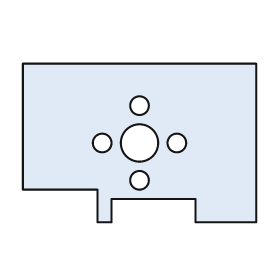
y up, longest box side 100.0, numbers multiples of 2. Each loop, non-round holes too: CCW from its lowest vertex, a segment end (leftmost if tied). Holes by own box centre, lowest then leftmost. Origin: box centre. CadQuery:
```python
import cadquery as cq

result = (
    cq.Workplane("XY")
    .moveTo(-18.0, -34.0)
    .lineTo(-12.0, -34.0)
    .lineTo(-12.0, -24.0)
    .lineTo(24.0, -24.0)
    .lineTo(24.0, -34.0)
    .lineTo(50.0, -34.0)
    .lineTo(50.0, 34.0)
    .lineTo(-50.0, 34.0)
    .lineTo(-50.0, -20.0)
    .lineTo(-18.0, -20.0)
    .close()
    .moveTo(0.0, -16.0)
    .circle(4.0)
    .moveTo(-16.0, 0.0)
    .circle(4.0)
    .moveTo(0.0, 0.0)
    .circle(8.0)
    .moveTo(16.0, 0.0)
    .circle(4.0)
    .moveTo(0.0, 16.0)
    .circle(4.0)
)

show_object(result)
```